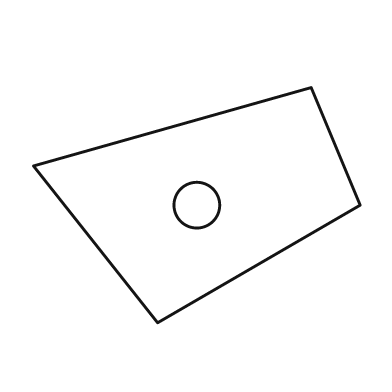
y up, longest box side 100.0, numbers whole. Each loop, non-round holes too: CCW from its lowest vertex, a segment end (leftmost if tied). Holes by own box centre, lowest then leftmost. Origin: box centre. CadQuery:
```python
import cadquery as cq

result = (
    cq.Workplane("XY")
    .moveTo(-12.0, -36.0)
    .lineTo(50.0, 0.0)
    .lineTo(35.0, 36.0)
    .lineTo(-50.0, 12.0)
    .close()
    .moveTo(0.0, 0.0)
    .circle(7.0)
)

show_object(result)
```